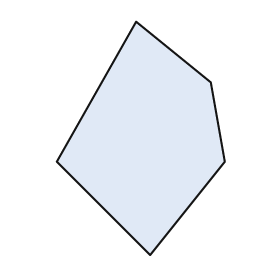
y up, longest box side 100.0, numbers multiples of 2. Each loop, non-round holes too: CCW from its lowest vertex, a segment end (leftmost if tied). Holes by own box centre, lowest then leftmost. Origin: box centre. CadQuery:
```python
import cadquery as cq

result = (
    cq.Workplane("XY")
    .moveTo(4.0, -50.0)
    .lineTo(36.0, -10.0)
    .lineTo(30.0, 24.0)
    .lineTo(-2.0, 50.0)
    .lineTo(-36.0, -10.0)
    .close()
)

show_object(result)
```